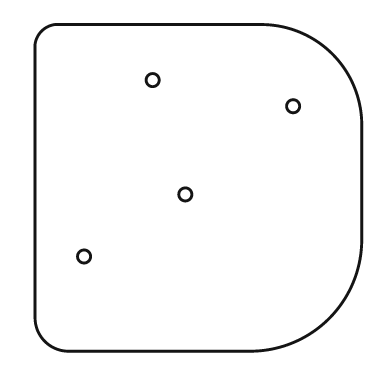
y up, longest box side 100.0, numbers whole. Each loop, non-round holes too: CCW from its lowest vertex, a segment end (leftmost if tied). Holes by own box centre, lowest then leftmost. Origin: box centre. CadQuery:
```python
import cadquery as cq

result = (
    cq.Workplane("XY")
    .moveTo(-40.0, -50.0)
    .lineTo(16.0, -50.0)
    .threePointArc((40.0, -40.0), (50.0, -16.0))
    .lineTo(50.0, 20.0)
    .threePointArc((41.0, 41.0), (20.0, 50.0))
    .lineTo(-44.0, 50.0)
    .threePointArc((-48.0, 48.0), (-50.0, 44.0))
    .lineTo(-50.0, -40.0)
    .threePointArc((-47.0, -47.0), (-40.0, -50.0))
    .close()
    .moveTo(-35.0, -21.0)
    .circle(2.0)
    .moveTo(-4.0, -2.0)
    .circle(2.0)
    .moveTo(29.0, 25.0)
    .circle(2.0)
    .moveTo(-14.0, 33.0)
    .circle(2.0)
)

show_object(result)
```